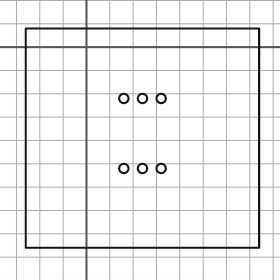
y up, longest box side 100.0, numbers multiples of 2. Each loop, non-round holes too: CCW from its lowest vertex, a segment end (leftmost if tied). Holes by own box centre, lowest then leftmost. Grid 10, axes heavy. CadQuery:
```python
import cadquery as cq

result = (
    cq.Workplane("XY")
    .moveTo(-26.0, -86.0)
    .lineTo(74.0, -86.0)
    .lineTo(74.0, 8.0)
    .lineTo(-26.0, 8.0)
    .close()
    .moveTo(16.0, -52.0)
    .circle(2.0)
    .moveTo(24.0, -52.0)
    .circle(2.0)
    .moveTo(32.0, -52.0)
    .circle(2.0)
    .moveTo(16.0, -22.0)
    .circle(2.0)
    .moveTo(24.0, -22.0)
    .circle(2.0)
    .moveTo(32.0, -22.0)
    .circle(2.0)
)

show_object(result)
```